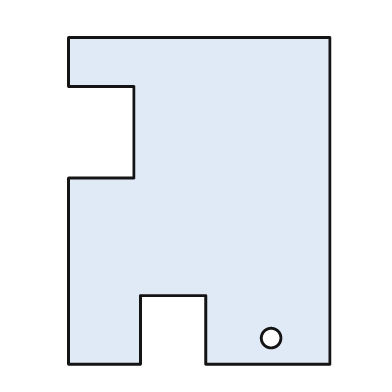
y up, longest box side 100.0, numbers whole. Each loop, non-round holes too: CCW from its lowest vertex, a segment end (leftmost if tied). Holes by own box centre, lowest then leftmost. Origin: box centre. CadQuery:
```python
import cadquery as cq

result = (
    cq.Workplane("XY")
    .moveTo(-40.0, -50.0)
    .lineTo(-18.0, -50.0)
    .lineTo(-18.0, -29.0)
    .lineTo(2.0, -29.0)
    .lineTo(2.0, -50.0)
    .lineTo(40.0, -50.0)
    .lineTo(40.0, 50.0)
    .lineTo(-40.0, 50.0)
    .lineTo(-40.0, 35.0)
    .lineTo(-20.0, 35.0)
    .lineTo(-20.0, 7.0)
    .lineTo(-40.0, 7.0)
    .close()
    .moveTo(22.0, -42.0)
    .circle(3.0)
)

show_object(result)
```